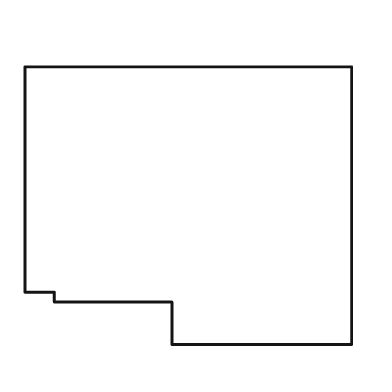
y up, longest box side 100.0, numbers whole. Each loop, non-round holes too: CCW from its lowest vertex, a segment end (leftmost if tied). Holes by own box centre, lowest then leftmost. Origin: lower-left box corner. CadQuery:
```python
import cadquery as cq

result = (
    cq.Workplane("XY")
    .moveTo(45.0, 0.0)
    .lineTo(100.0, 0.0)
    .lineTo(100.0, 85.0)
    .lineTo(0.0, 85.0)
    .lineTo(0.0, 16.0)
    .lineTo(9.0, 16.0)
    .lineTo(9.0, 13.0)
    .lineTo(45.0, 13.0)
    .close()
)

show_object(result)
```